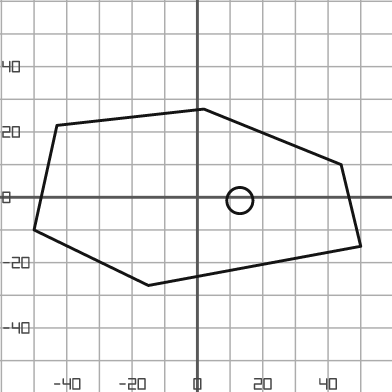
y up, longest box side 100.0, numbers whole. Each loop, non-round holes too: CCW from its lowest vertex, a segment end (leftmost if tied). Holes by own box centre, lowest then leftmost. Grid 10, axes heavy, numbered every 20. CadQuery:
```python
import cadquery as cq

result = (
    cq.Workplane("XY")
    .moveTo(-15.0, -27.0)
    .lineTo(50.0, -15.0)
    .lineTo(44.0, 10.0)
    .lineTo(2.0, 27.0)
    .lineTo(-43.0, 22.0)
    .lineTo(-50.0, -10.0)
    .close()
    .moveTo(13.0, -1.0)
    .circle(4.0)
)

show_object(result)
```